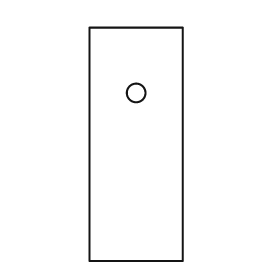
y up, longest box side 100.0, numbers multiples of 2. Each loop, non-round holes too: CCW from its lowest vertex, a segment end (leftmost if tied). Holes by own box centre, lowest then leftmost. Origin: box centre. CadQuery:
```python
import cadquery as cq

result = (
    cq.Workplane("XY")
    .moveTo(-20.0, -50.0)
    .lineTo(20.0, -50.0)
    .lineTo(20.0, 50.0)
    .lineTo(-20.0, 50.0)
    .close()
    .moveTo(0.0, 22.0)
    .circle(4.0)
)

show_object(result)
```